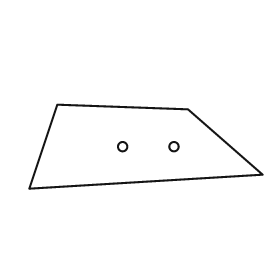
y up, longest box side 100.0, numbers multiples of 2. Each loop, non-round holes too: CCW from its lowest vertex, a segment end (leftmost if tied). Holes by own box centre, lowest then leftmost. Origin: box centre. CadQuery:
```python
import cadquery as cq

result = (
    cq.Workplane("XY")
    .moveTo(-50.0, -18.0)
    .lineTo(50.0, -12.0)
    .lineTo(18.0, 16.0)
    .lineTo(-38.0, 18.0)
    .close()
    .moveTo(-10.0, 0.0)
    .circle(2.0)
    .moveTo(12.0, 0.0)
    .circle(2.0)
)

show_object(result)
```